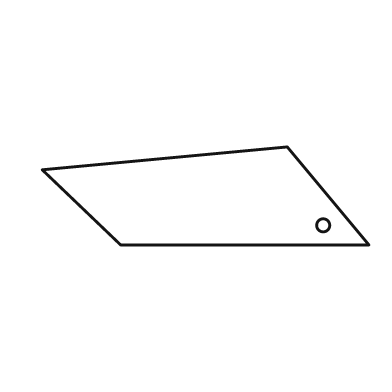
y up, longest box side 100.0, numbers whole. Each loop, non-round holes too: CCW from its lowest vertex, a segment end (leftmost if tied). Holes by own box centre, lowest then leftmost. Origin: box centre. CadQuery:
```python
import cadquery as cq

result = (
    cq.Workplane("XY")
    .moveTo(-26.0, -15.0)
    .lineTo(50.0, -15.0)
    .lineTo(25.0, 15.0)
    .lineTo(-50.0, 8.0)
    .close()
    .moveTo(36.0, -9.0)
    .circle(2.0)
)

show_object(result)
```